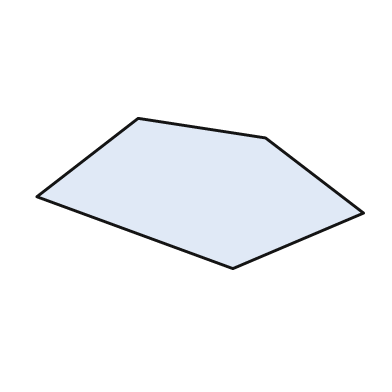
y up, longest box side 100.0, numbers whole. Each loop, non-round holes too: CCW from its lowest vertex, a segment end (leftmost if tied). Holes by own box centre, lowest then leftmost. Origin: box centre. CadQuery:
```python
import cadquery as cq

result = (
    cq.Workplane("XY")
    .moveTo(10.0, -23.0)
    .lineTo(50.0, -6.0)
    .lineTo(20.0, 17.0)
    .lineTo(-19.0, 23.0)
    .lineTo(-50.0, -1.0)
    .close()
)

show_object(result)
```